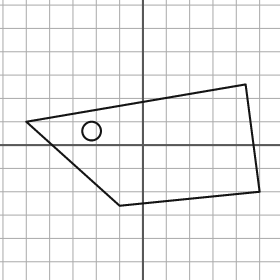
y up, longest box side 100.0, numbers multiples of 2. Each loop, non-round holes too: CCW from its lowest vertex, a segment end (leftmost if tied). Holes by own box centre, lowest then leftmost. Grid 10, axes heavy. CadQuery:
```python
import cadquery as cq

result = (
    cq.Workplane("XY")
    .moveTo(-10.0, -26.0)
    .lineTo(50.0, -20.0)
    .lineTo(44.0, 26.0)
    .lineTo(-50.0, 10.0)
    .close()
    .moveTo(-22.0, 6.0)
    .circle(4.0)
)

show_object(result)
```